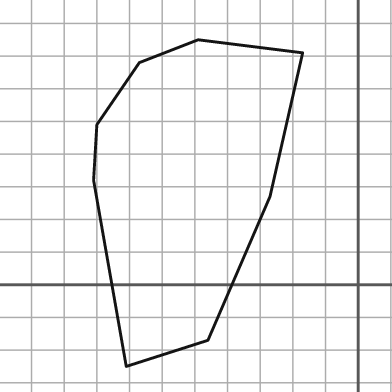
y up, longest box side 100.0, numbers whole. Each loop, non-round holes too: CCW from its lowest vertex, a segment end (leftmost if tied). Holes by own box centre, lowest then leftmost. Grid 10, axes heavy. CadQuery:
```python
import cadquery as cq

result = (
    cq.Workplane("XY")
    .moveTo(-71.0, -25.0)
    .lineTo(-46.0, -17.0)
    .lineTo(-27.0, 27.0)
    .lineTo(-17.0, 71.0)
    .lineTo(-49.0, 75.0)
    .lineTo(-67.0, 68.0)
    .lineTo(-80.0, 49.0)
    .lineTo(-81.0, 32.0)
    .close()
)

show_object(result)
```